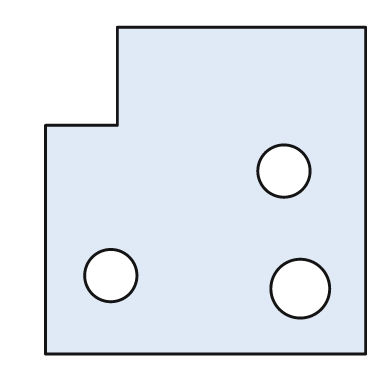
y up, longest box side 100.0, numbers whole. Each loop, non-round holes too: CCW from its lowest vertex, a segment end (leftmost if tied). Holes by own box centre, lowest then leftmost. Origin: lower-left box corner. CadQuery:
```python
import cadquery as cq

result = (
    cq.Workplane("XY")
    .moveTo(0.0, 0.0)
    .lineTo(98.0, 0.0)
    .lineTo(98.0, 100.0)
    .lineTo(22.0, 100.0)
    .lineTo(22.0, 70.0)
    .lineTo(0.0, 70.0)
    .close()
    .moveTo(78.0, 20.0)
    .circle(9.0)
    .moveTo(20.0, 24.0)
    .circle(8.0)
    .moveTo(73.0, 56.0)
    .circle(8.0)
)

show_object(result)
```